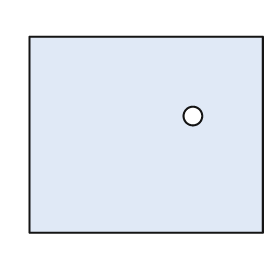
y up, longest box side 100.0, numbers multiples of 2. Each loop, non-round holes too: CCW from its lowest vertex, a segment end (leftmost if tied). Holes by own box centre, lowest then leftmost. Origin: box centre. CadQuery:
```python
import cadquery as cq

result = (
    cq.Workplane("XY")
    .moveTo(-50.0, -42.0)
    .lineTo(50.0, -42.0)
    .lineTo(50.0, 42.0)
    .lineTo(-50.0, 42.0)
    .close()
    .moveTo(20.0, 8.0)
    .circle(4.0)
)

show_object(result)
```